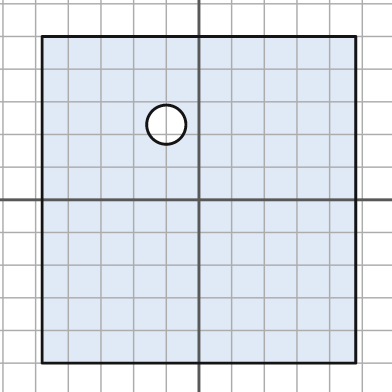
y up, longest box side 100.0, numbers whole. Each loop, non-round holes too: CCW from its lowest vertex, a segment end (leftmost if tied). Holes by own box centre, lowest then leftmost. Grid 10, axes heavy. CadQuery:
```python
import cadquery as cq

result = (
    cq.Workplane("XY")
    .moveTo(-48.0, -50.0)
    .lineTo(48.0, -50.0)
    .lineTo(48.0, 50.0)
    .lineTo(-48.0, 50.0)
    .close()
    .moveTo(-10.0, 23.0)
    .circle(6.0)
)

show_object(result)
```